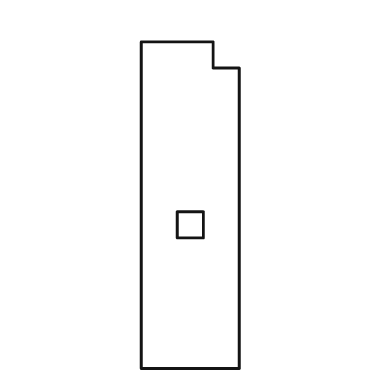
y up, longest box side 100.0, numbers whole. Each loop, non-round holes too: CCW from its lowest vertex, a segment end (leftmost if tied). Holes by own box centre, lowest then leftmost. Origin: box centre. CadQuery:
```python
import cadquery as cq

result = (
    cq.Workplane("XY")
    .moveTo(-15.0, -50.0)
    .lineTo(15.0, -50.0)
    .lineTo(15.0, 42.0)
    .lineTo(7.0, 42.0)
    .lineTo(7.0, 50.0)
    .lineTo(-15.0, 50.0)
    .close()
    .moveTo(-4.0, -10.0)
    .lineTo(4.0, -10.0)
    .lineTo(4.0, -2.0)
    .lineTo(-4.0, -2.0)
    .close()
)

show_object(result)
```